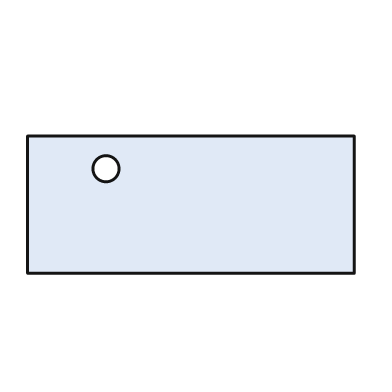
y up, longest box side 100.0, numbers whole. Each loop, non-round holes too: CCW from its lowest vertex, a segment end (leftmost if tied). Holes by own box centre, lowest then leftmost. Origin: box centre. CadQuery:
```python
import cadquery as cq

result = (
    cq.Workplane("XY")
    .moveTo(-50.0, -21.0)
    .lineTo(50.0, -21.0)
    .lineTo(50.0, 21.0)
    .lineTo(-50.0, 21.0)
    .close()
    .moveTo(-26.0, 11.0)
    .circle(4.0)
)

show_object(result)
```